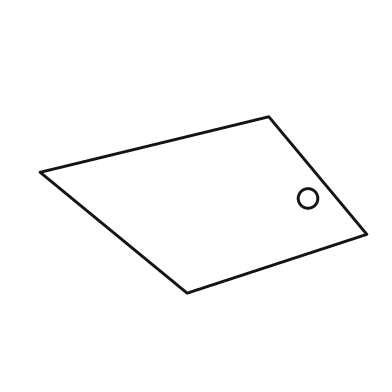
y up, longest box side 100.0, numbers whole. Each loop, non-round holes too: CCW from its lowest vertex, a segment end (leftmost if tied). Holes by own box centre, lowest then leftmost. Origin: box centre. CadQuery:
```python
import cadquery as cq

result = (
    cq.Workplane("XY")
    .moveTo(-5.0, -27.0)
    .lineTo(50.0, -9.0)
    .lineTo(20.0, 27.0)
    .lineTo(-50.0, 10.0)
    .close()
    .moveTo(32.0, 2.0)
    .circle(3.0)
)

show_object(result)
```